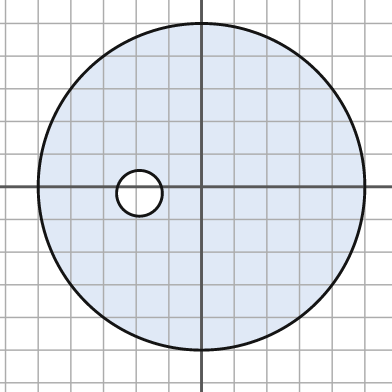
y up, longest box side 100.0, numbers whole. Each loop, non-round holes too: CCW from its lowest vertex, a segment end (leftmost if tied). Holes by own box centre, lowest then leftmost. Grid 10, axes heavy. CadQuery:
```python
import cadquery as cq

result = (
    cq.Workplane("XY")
    .moveTo(0.0, 0.0)
    .circle(50.0)
    .moveTo(-19.0, -2.0)
    .circle(7.0)
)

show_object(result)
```